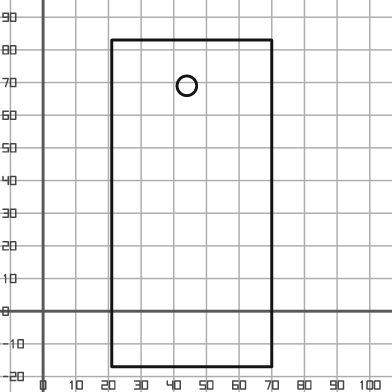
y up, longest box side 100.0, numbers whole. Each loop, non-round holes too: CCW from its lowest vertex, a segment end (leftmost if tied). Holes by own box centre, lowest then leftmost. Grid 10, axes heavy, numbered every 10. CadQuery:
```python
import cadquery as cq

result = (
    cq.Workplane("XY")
    .moveTo(21.0, -17.0)
    .lineTo(70.0, -17.0)
    .lineTo(70.0, 83.0)
    .lineTo(21.0, 83.0)
    .close()
    .moveTo(44.0, 69.0)
    .circle(3.0)
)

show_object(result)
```